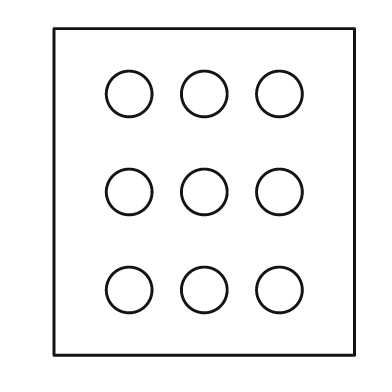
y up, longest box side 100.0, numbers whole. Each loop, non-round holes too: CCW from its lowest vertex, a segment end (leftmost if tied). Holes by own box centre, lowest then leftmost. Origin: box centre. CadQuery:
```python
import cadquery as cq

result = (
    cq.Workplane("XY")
    .moveTo(-46.0, -50.0)
    .lineTo(46.0, -50.0)
    .lineTo(46.0, 50.0)
    .lineTo(-46.0, 50.0)
    .close()
    .moveTo(-23.0, -30.0)
    .circle(7.0)
    .moveTo(0.0, -30.0)
    .circle(7.0)
    .moveTo(23.0, -30.0)
    .circle(7.0)
    .moveTo(-23.0, 0.0)
    .circle(7.0)
    .moveTo(0.0, 0.0)
    .circle(7.0)
    .moveTo(23.0, 0.0)
    .circle(7.0)
    .moveTo(-23.0, 30.0)
    .circle(7.0)
    .moveTo(0.0, 30.0)
    .circle(7.0)
    .moveTo(23.0, 30.0)
    .circle(7.0)
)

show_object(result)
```